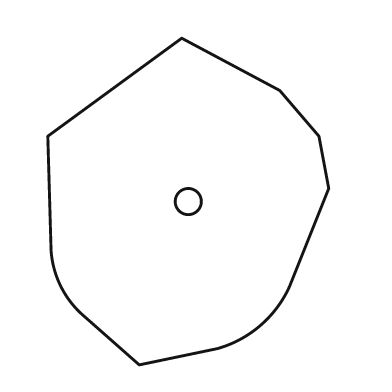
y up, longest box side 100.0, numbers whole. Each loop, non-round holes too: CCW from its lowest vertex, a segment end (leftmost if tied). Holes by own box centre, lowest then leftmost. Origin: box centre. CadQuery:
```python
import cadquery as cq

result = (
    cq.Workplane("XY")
    .moveTo(-15.0, -50.0)
    .lineTo(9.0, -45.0)
    .threePointArc((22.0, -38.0), (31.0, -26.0))
    .lineTo(43.0, 4.0)
    .lineTo(40.0, 20.0)
    .lineTo(28.0, 34.0)
    .lineTo(-2.0, 50.0)
    .lineTo(-43.0, 20.0)
    .lineTo(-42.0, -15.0)
    .threePointArc((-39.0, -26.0), (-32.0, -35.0))
    .close()
    .moveTo(0.0, 0.0)
    .circle(4.0)
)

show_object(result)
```